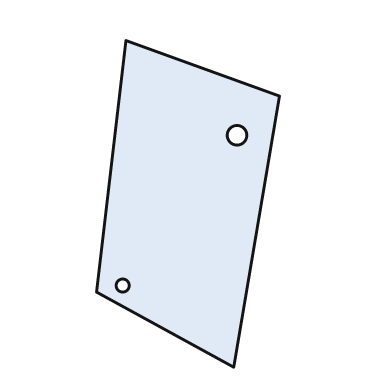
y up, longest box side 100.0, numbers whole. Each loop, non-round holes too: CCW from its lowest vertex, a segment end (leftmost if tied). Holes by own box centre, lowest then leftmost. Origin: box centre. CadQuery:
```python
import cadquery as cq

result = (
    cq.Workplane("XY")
    .moveTo(14.0, -50.0)
    .lineTo(28.0, 33.0)
    .lineTo(-19.0, 50.0)
    .lineTo(-28.0, -27.0)
    .close()
    .moveTo(-20.0, -25.0)
    .circle(2.0)
    .moveTo(15.0, 21.0)
    .circle(3.0)
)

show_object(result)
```